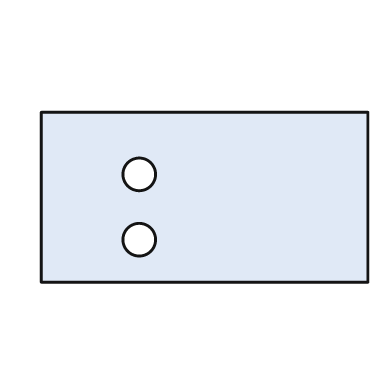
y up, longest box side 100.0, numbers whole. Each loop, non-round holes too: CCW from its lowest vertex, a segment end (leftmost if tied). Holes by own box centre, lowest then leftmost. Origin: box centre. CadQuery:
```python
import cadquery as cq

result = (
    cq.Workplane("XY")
    .moveTo(-50.0, -26.0)
    .lineTo(50.0, -26.0)
    .lineTo(50.0, 26.0)
    .lineTo(-50.0, 26.0)
    .close()
    .moveTo(-20.0, -13.0)
    .circle(5.0)
    .moveTo(-20.0, 7.0)
    .circle(5.0)
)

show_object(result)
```